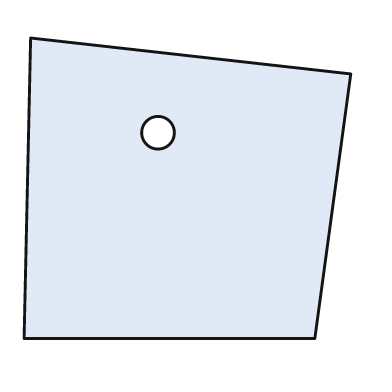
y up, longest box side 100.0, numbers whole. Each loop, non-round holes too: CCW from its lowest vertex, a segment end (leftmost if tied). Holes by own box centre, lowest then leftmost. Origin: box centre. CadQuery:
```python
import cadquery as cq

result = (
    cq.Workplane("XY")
    .moveTo(-50.0, -46.0)
    .lineTo(39.0, -46.0)
    .lineTo(50.0, 35.0)
    .lineTo(-48.0, 46.0)
    .close()
    .moveTo(-9.0, 17.0)
    .circle(5.0)
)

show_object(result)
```